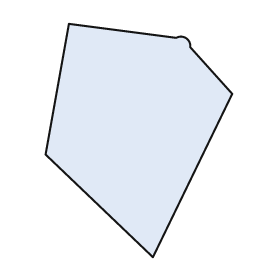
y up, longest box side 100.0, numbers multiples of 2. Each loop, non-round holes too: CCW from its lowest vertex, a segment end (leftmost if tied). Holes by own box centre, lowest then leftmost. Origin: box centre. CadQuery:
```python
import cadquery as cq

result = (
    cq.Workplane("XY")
    .moveTo(6.0, -50.0)
    .lineTo(40.0, 20.0)
    .lineTo(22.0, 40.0)
    .threePointArc((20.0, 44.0), (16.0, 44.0))
    .lineTo(-30.0, 50.0)
    .lineTo(-40.0, -6.0)
    .close()
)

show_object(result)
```